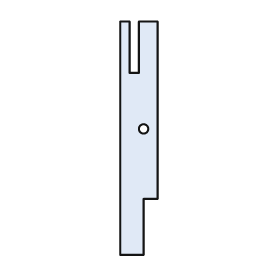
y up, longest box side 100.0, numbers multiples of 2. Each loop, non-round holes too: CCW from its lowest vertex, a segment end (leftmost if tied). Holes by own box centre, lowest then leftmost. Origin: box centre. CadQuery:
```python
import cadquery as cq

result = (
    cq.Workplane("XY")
    .moveTo(-8.0, -50.0)
    .lineTo(2.0, -50.0)
    .lineTo(2.0, -26.0)
    .lineTo(8.0, -26.0)
    .lineTo(8.0, 50.0)
    .lineTo(0.0, 50.0)
    .lineTo(0.0, 28.0)
    .lineTo(-4.0, 28.0)
    .lineTo(-4.0, 50.0)
    .lineTo(-8.0, 50.0)
    .close()
    .moveTo(2.0, 4.0)
    .circle(2.0)
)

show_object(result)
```